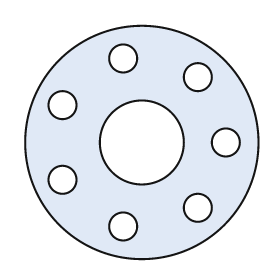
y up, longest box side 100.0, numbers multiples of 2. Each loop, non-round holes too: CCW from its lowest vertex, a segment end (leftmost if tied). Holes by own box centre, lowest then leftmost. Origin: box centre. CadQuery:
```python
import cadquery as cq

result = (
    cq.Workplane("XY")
    .moveTo(0.0, 0.0)
    .circle(50.0)
    .moveTo(-8.0, -36.0)
    .circle(6.0)
    .moveTo(24.0, -28.0)
    .circle(6.0)
    .moveTo(-34.0, -16.0)
    .circle(6.0)
    .moveTo(0.0, 0.0)
    .circle(18.0)
    .moveTo(36.0, 0.0)
    .circle(6.0)
    .moveTo(-34.0, 16.0)
    .circle(6.0)
    .moveTo(24.0, 28.0)
    .circle(6.0)
    .moveTo(-8.0, 36.0)
    .circle(6.0)
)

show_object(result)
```